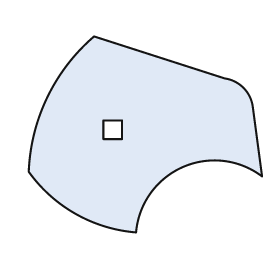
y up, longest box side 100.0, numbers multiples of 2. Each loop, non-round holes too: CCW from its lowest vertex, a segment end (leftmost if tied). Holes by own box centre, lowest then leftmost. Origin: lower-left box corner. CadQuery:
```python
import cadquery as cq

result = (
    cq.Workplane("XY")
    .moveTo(46.0, 0.0)
    .threePointArc((66.0, 28.0), (100.0, 24.0))
    .lineTo(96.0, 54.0)
    .threePointArc((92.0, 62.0), (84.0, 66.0))
    .lineTo(28.0, 84.0)
    .threePointArc((8.0, 58.0), (0.0, 26.0))
    .threePointArc((20.0, 8.0), (46.0, 0.0))
    .close()
    .moveTo(32.0, 40.0)
    .lineTo(40.0, 40.0)
    .lineTo(40.0, 48.0)
    .lineTo(32.0, 48.0)
    .close()
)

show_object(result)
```